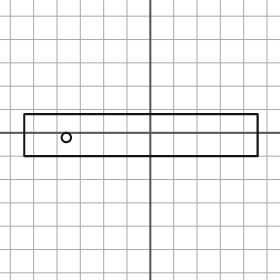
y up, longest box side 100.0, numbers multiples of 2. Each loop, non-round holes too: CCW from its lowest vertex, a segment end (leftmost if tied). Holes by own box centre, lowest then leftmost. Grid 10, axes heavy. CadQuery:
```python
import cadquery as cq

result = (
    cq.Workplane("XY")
    .moveTo(-54.0, -10.0)
    .lineTo(46.0, -10.0)
    .lineTo(46.0, 8.0)
    .lineTo(-54.0, 8.0)
    .close()
    .moveTo(-36.0, -2.0)
    .circle(2.0)
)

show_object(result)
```